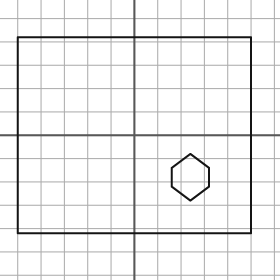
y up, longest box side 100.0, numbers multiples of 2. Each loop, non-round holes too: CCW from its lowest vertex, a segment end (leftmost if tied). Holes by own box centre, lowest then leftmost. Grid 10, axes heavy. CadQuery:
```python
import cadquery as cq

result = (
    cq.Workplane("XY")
    .moveTo(-50.0, -42.0)
    .lineTo(50.0, -42.0)
    .lineTo(50.0, 42.0)
    .lineTo(-50.0, 42.0)
    .close()
    .moveTo(24.0, -28.0)
    .lineTo(32.0, -22.0)
    .lineTo(32.0, -14.0)
    .lineTo(24.0, -8.0)
    .lineTo(16.0, -14.0)
    .lineTo(16.0, -22.0)
    .close()
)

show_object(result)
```